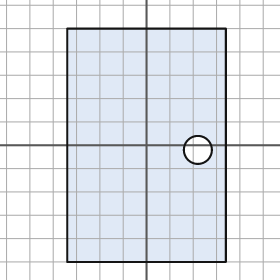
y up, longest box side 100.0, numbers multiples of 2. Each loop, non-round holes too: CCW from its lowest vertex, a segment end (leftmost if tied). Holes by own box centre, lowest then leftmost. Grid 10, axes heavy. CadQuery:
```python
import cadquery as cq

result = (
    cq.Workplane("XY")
    .moveTo(-34.0, -50.0)
    .lineTo(34.0, -50.0)
    .lineTo(34.0, 50.0)
    .lineTo(-34.0, 50.0)
    .close()
    .moveTo(22.0, -2.0)
    .circle(6.0)
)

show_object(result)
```